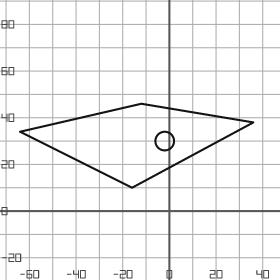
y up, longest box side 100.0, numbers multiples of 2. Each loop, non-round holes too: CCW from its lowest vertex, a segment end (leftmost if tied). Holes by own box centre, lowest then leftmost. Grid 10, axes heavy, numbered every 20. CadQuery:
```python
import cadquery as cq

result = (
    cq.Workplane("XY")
    .moveTo(-16.0, 10.0)
    .lineTo(36.0, 38.0)
    .lineTo(-12.0, 46.0)
    .lineTo(-64.0, 34.0)
    .close()
    .moveTo(-2.0, 30.0)
    .circle(4.0)
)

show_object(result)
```